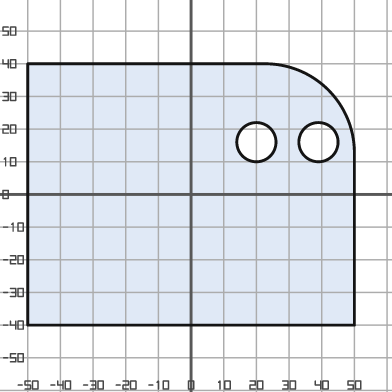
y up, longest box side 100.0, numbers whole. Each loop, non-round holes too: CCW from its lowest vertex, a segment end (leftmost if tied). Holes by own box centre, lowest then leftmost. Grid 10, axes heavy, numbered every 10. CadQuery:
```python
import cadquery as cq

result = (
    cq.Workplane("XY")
    .moveTo(-50.0, -40.0)
    .lineTo(50.0, -40.0)
    .lineTo(50.0, 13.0)
    .threePointArc((42.0, 32.0), (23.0, 40.0))
    .lineTo(-50.0, 40.0)
    .close()
    .moveTo(20.0, 16.0)
    .circle(6.0)
    .moveTo(39.0, 16.0)
    .circle(6.0)
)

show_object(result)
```